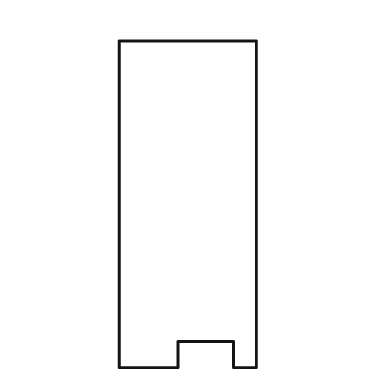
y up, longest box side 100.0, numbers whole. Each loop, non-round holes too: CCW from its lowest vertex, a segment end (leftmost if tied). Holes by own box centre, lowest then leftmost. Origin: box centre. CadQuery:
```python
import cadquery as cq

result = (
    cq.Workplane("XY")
    .moveTo(-21.0, -50.0)
    .lineTo(-3.0, -50.0)
    .lineTo(-3.0, -42.0)
    .lineTo(14.0, -42.0)
    .lineTo(14.0, -50.0)
    .lineTo(21.0, -50.0)
    .lineTo(21.0, 50.0)
    .lineTo(-21.0, 50.0)
    .close()
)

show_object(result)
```